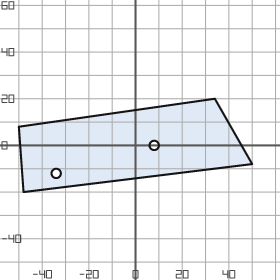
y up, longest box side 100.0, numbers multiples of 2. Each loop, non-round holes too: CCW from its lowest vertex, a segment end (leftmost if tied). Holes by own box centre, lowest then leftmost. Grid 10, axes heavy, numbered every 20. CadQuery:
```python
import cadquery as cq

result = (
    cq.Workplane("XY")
    .moveTo(-48.0, -20.0)
    .lineTo(50.0, -8.0)
    .lineTo(34.0, 20.0)
    .lineTo(-50.0, 8.0)
    .close()
    .moveTo(-34.0, -12.0)
    .circle(2.0)
    .moveTo(8.0, 0.0)
    .circle(2.0)
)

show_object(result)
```